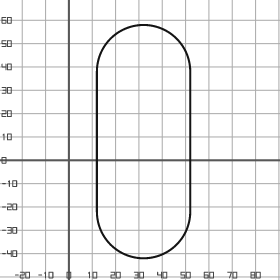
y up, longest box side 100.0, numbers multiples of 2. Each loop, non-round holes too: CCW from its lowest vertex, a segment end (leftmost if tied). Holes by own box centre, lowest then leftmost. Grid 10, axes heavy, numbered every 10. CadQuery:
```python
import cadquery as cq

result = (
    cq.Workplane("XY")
    .moveTo(12.0, -22.0)
    .threePointArc((32.0, -42.0), (52.0, -22.0))
    .lineTo(52.0, 38.0)
    .threePointArc((32.0, 58.0), (12.0, 38.0))
    .close()
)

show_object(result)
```